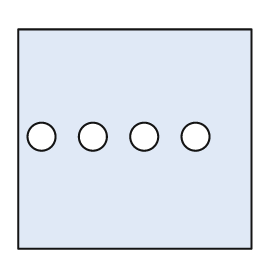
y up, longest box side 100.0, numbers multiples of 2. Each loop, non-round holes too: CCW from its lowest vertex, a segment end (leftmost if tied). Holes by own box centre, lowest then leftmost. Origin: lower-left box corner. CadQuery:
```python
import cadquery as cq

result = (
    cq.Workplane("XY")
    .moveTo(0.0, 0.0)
    .lineTo(100.0, 0.0)
    .lineTo(100.0, 94.0)
    .lineTo(0.0, 94.0)
    .close()
    .moveTo(10.0, 48.0)
    .circle(6.0)
    .moveTo(32.0, 48.0)
    .circle(6.0)
    .moveTo(54.0, 48.0)
    .circle(6.0)
    .moveTo(76.0, 48.0)
    .circle(6.0)
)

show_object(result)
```